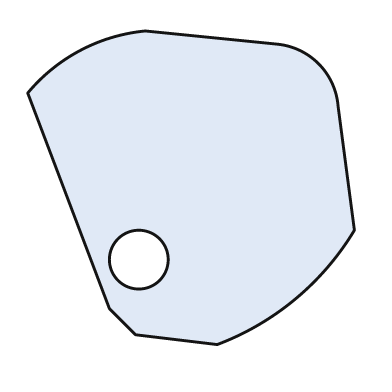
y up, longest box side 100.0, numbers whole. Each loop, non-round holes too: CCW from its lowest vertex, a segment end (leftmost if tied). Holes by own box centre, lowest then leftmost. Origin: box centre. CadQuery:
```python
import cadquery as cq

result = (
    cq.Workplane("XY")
    .moveTo(8.0, -48.0)
    .threePointArc((32.0, -34.0), (50.0, -13.0))
    .lineTo(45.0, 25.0)
    .threePointArc((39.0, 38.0), (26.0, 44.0))
    .lineTo(-14.0, 48.0)
    .threePointArc((-34.0, 42.0), (-50.0, 29.0))
    .lineTo(-25.0, -37.0)
    .lineTo(-17.0, -45.0)
    .close()
    .moveTo(-16.0, -22.0)
    .circle(9.0)
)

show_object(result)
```